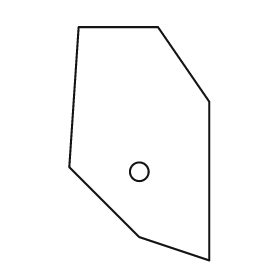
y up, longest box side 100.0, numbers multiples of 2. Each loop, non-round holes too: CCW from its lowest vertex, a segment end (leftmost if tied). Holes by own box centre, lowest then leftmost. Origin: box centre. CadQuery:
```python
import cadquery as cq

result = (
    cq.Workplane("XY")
    .moveTo(30.0, -50.0)
    .lineTo(30.0, 18.0)
    .lineTo(8.0, 50.0)
    .lineTo(-26.0, 50.0)
    .lineTo(-30.0, -10.0)
    .lineTo(0.0, -40.0)
    .close()
    .moveTo(0.0, -12.0)
    .circle(4.0)
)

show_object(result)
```